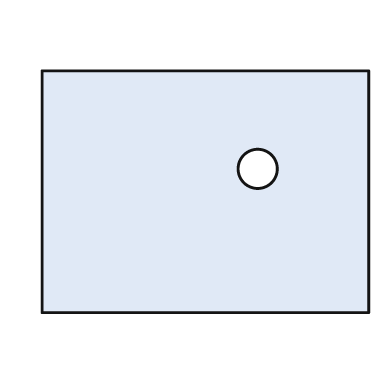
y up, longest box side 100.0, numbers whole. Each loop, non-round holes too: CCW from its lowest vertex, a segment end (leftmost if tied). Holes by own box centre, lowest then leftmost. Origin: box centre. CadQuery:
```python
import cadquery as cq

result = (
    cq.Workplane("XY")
    .moveTo(-50.0, -37.0)
    .lineTo(50.0, -37.0)
    .lineTo(50.0, 37.0)
    .lineTo(-50.0, 37.0)
    .close()
    .moveTo(16.0, 7.0)
    .circle(6.0)
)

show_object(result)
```